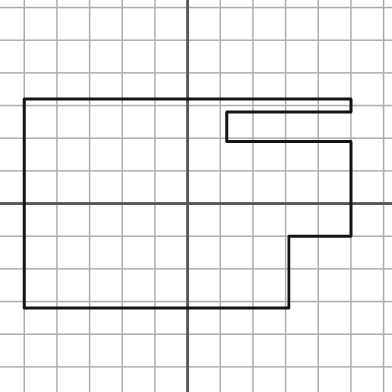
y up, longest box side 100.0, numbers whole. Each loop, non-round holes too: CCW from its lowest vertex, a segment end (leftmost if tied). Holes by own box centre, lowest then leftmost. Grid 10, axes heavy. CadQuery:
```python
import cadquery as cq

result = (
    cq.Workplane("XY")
    .moveTo(-50.0, -32.0)
    .lineTo(31.0, -32.0)
    .lineTo(31.0, -10.0)
    .lineTo(50.0, -10.0)
    .lineTo(50.0, 19.0)
    .lineTo(12.0, 19.0)
    .lineTo(12.0, 28.0)
    .lineTo(50.0, 28.0)
    .lineTo(50.0, 32.0)
    .lineTo(-50.0, 32.0)
    .close()
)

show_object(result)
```